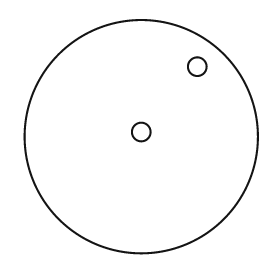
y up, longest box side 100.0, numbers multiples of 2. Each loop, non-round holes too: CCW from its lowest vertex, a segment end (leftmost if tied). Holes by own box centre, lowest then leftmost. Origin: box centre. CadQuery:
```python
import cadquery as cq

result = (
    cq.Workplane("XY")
    .moveTo(0.0, 0.0)
    .circle(50.0)
    .moveTo(0.0, 2.0)
    .circle(4.0)
    .moveTo(24.0, 30.0)
    .circle(4.0)
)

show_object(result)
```